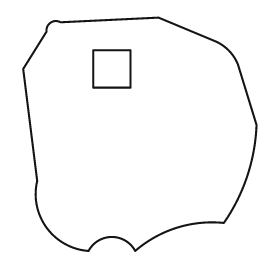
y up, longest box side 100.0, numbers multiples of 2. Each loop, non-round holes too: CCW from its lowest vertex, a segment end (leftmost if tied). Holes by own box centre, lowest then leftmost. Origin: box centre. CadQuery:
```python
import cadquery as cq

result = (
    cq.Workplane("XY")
    .moveTo(-22.0, -50.0)
    .threePointArc((-12.0, -44.0), (-2.0, -50.0))
    .threePointArc((16.0, -40.0), (36.0, -38.0))
    .threePointArc((46.0, -18.0), (50.0, 4.0))
    .lineTo(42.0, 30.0)
    .threePointArc((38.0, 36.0), (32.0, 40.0))
    .lineTo(8.0, 50.0)
    .lineTo(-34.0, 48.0)
    .threePointArc((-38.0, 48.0), (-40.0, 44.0))
    .lineTo(-50.0, 28.0)
    .lineTo(-44.0, -20.0)
    .threePointArc((-40.0, -40.0), (-22.0, -50.0))
    .close()
    .moveTo(-20.0, 20.0)
    .lineTo(-4.0, 20.0)
    .lineTo(-4.0, 36.0)
    .lineTo(-20.0, 36.0)
    .close()
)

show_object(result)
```